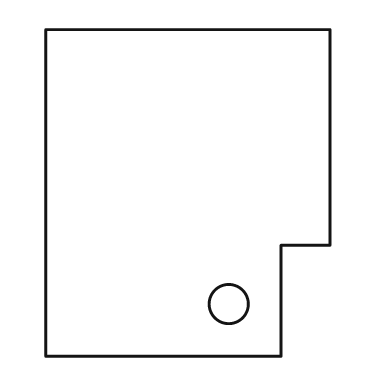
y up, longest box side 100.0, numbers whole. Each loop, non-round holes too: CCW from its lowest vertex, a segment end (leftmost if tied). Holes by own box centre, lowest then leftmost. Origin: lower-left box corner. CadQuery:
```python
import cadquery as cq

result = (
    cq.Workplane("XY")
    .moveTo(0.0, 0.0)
    .lineTo(72.0, 0.0)
    .lineTo(72.0, 34.0)
    .lineTo(87.0, 34.0)
    .lineTo(87.0, 100.0)
    .lineTo(0.0, 100.0)
    .close()
    .moveTo(56.0, 16.0)
    .circle(6.0)
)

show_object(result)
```